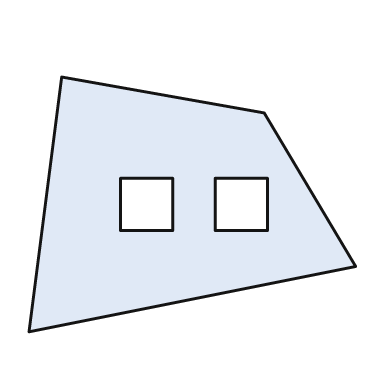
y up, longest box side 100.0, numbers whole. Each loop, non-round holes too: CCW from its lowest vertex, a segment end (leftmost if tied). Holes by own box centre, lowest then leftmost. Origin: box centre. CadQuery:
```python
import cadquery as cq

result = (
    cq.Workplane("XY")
    .moveTo(-50.0, -39.0)
    .lineTo(50.0, -19.0)
    .lineTo(22.0, 28.0)
    .lineTo(-40.0, 39.0)
    .close()
    .moveTo(-22.0, -8.0)
    .lineTo(-6.0, -8.0)
    .lineTo(-6.0, 8.0)
    .lineTo(-22.0, 8.0)
    .close()
    .moveTo(7.0, -8.0)
    .lineTo(23.0, -8.0)
    .lineTo(23.0, 8.0)
    .lineTo(7.0, 8.0)
    .close()
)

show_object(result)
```